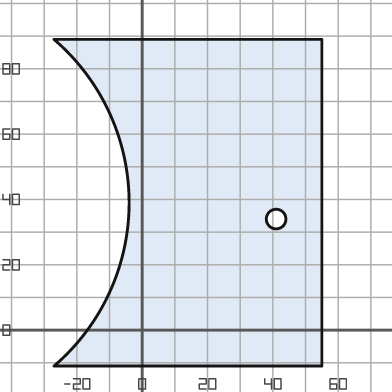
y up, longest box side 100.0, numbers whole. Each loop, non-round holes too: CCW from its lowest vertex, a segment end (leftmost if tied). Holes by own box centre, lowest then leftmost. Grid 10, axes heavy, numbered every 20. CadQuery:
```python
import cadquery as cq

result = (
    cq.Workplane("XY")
    .moveTo(-27.0, -11.0)
    .lineTo(55.0, -11.0)
    .lineTo(55.0, 89.0)
    .lineTo(-27.0, 89.0)
    .threePointArc((-4.0, 39.0), (-27.0, -11.0))
    .close()
    .moveTo(41.0, 34.0)
    .circle(3.0)
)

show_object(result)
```